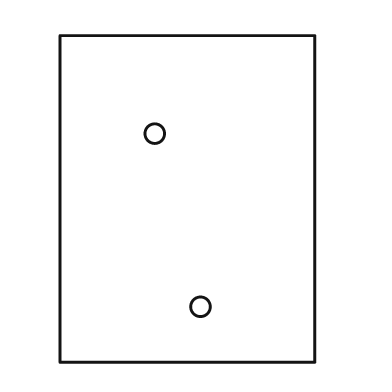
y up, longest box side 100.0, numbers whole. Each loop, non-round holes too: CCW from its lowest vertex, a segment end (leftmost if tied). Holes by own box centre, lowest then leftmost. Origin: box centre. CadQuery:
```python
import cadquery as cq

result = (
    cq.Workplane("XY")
    .moveTo(-39.0, -50.0)
    .lineTo(39.0, -50.0)
    .lineTo(39.0, 50.0)
    .lineTo(-39.0, 50.0)
    .close()
    .moveTo(4.0, -33.0)
    .circle(3.0)
    .moveTo(-10.0, 20.0)
    .circle(3.0)
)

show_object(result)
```